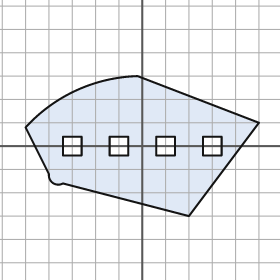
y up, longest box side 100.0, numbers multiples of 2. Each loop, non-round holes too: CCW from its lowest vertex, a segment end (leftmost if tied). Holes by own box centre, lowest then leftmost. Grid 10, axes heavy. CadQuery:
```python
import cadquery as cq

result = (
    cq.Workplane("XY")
    .moveTo(20.0, -30.0)
    .lineTo(50.0, 10.0)
    .lineTo(-2.0, 30.0)
    .threePointArc((-28.0, 24.0), (-50.0, 8.0))
    .lineTo(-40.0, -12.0)
    .threePointArc((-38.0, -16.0), (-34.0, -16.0))
    .close()
    .moveTo(-34.0, -4.0)
    .lineTo(-26.0, -4.0)
    .lineTo(-26.0, 4.0)
    .lineTo(-34.0, 4.0)
    .close()
    .moveTo(-14.0, -4.0)
    .lineTo(-6.0, -4.0)
    .lineTo(-6.0, 4.0)
    .lineTo(-14.0, 4.0)
    .close()
    .moveTo(6.0, -4.0)
    .lineTo(14.0, -4.0)
    .lineTo(14.0, 4.0)
    .lineTo(6.0, 4.0)
    .close()
    .moveTo(26.0, -4.0)
    .lineTo(34.0, -4.0)
    .lineTo(34.0, 4.0)
    .lineTo(26.0, 4.0)
    .close()
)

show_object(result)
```